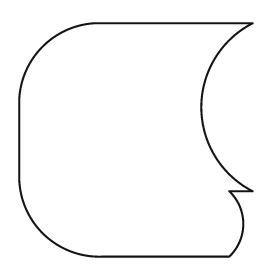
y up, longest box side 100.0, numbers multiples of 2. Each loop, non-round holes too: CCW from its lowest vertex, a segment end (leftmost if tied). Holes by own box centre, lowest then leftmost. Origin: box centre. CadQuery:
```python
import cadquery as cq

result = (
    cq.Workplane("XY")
    .moveTo(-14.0, -50.0)
    .lineTo(40.0, -50.0)
    .threePointArc((46.0, -36.0), (40.0, -22.0))
    .lineTo(50.0, -22.0)
    .threePointArc((28.0, 14.0), (50.0, 50.0))
    .lineTo(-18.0, 50.0)
    .threePointArc((-40.0, 40.0), (-50.0, 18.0))
    .lineTo(-50.0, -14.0)
    .threePointArc((-40.0, -40.0), (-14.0, -50.0))
    .close()
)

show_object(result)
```